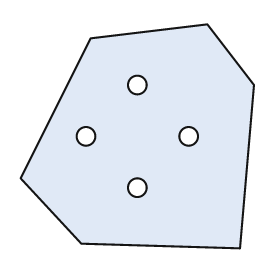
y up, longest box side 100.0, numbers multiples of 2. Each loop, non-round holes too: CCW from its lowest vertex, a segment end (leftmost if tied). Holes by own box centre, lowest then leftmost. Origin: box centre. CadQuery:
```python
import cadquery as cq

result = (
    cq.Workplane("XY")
    .moveTo(44.0, -48.0)
    .lineTo(50.0, 22.0)
    .lineTo(30.0, 48.0)
    .lineTo(-20.0, 42.0)
    .lineTo(-50.0, -18.0)
    .lineTo(-24.0, -46.0)
    .close()
    .moveTo(0.0, -22.0)
    .circle(4.0)
    .moveTo(-22.0, 0.0)
    .circle(4.0)
    .moveTo(22.0, 0.0)
    .circle(4.0)
    .moveTo(0.0, 22.0)
    .circle(4.0)
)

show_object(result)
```